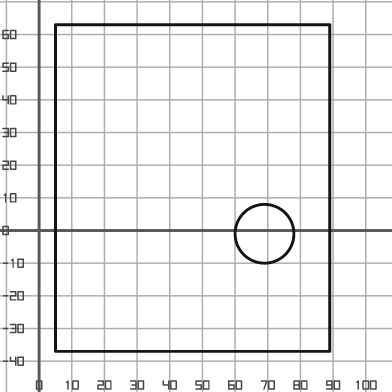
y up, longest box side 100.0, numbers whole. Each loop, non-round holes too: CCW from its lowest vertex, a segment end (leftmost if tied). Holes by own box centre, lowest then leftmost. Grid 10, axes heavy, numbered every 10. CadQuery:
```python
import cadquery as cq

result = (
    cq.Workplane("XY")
    .moveTo(5.0, -37.0)
    .lineTo(89.0, -37.0)
    .lineTo(89.0, 63.0)
    .lineTo(5.0, 63.0)
    .close()
    .moveTo(69.0, -1.0)
    .circle(9.0)
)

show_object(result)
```